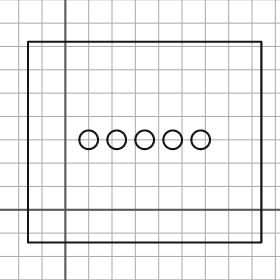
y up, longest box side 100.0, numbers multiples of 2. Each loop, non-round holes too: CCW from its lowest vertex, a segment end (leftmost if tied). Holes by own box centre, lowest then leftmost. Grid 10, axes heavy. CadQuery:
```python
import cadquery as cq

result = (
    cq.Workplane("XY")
    .moveTo(-16.0, -14.0)
    .lineTo(84.0, -14.0)
    .lineTo(84.0, 72.0)
    .lineTo(-16.0, 72.0)
    .close()
    .moveTo(10.0, 30.0)
    .circle(4.0)
    .moveTo(22.0, 30.0)
    .circle(4.0)
    .moveTo(34.0, 30.0)
    .circle(4.0)
    .moveTo(46.0, 30.0)
    .circle(4.0)
    .moveTo(58.0, 30.0)
    .circle(4.0)
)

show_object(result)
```